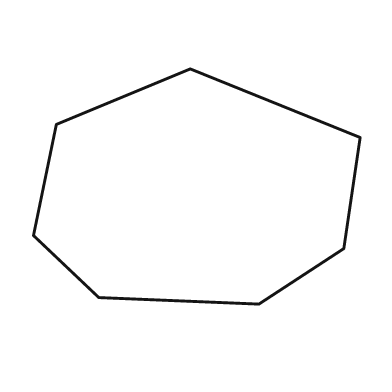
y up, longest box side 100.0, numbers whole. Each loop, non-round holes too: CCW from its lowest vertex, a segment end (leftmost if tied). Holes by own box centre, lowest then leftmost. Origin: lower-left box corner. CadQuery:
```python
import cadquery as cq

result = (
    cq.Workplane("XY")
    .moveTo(69.0, 0.0)
    .lineTo(95.0, 17.0)
    .lineTo(100.0, 51.0)
    .lineTo(48.0, 72.0)
    .lineTo(7.0, 55.0)
    .lineTo(0.0, 21.0)
    .lineTo(20.0, 2.0)
    .close()
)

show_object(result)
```